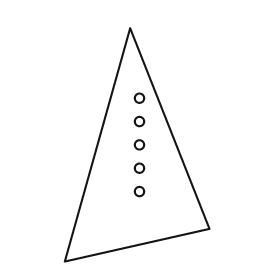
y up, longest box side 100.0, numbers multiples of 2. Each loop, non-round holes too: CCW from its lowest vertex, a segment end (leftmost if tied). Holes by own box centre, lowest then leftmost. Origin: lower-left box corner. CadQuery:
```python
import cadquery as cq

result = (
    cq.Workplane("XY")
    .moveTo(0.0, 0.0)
    .lineTo(62.0, 14.0)
    .lineTo(28.0, 100.0)
    .close()
    .moveTo(32.0, 30.0)
    .circle(2.0)
    .moveTo(32.0, 40.0)
    .circle(2.0)
    .moveTo(32.0, 50.0)
    .circle(2.0)
    .moveTo(32.0, 60.0)
    .circle(2.0)
    .moveTo(32.0, 70.0)
    .circle(2.0)
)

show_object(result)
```